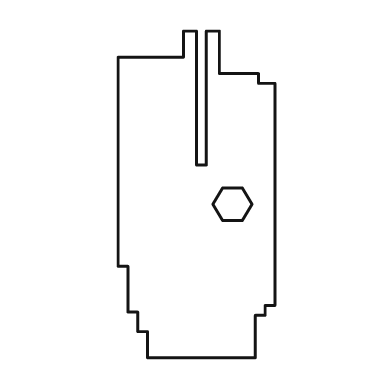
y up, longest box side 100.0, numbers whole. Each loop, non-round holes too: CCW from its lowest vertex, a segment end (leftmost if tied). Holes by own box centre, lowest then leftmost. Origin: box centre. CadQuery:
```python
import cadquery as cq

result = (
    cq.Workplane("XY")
    .moveTo(-15.0, -50.0)
    .lineTo(18.0, -50.0)
    .lineTo(18.0, -37.0)
    .lineTo(21.0, -37.0)
    .lineTo(21.0, -34.0)
    .lineTo(24.0, -34.0)
    .lineTo(24.0, 34.0)
    .lineTo(19.0, 34.0)
    .lineTo(19.0, 37.0)
    .lineTo(7.0, 37.0)
    .lineTo(7.0, 50.0)
    .lineTo(3.0, 50.0)
    .lineTo(3.0, 9.0)
    .lineTo(0.0, 9.0)
    .lineTo(0.0, 50.0)
    .lineTo(-4.0, 50.0)
    .lineTo(-4.0, 42.0)
    .lineTo(-24.0, 42.0)
    .lineTo(-24.0, -22.0)
    .lineTo(-21.0, -22.0)
    .lineTo(-21.0, -36.0)
    .lineTo(-18.0, -36.0)
    .lineTo(-18.0, -42.0)
    .lineTo(-15.0, -42.0)
    .close()
    .moveTo(8.0, -8.0)
    .lineTo(14.0, -8.0)
    .lineTo(17.0, -3.0)
    .lineTo(14.0, 2.0)
    .lineTo(8.0, 2.0)
    .lineTo(5.0, -3.0)
    .close()
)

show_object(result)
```